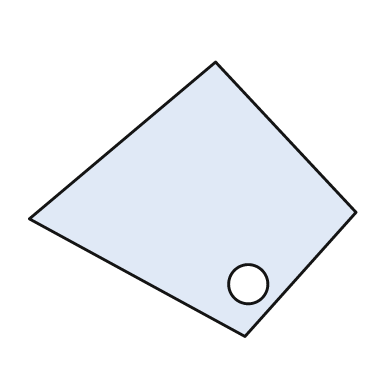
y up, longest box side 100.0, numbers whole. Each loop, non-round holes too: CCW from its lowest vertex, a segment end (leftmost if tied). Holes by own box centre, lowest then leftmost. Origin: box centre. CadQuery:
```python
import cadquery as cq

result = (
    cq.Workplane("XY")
    .moveTo(16.0, -42.0)
    .lineTo(50.0, -4.0)
    .lineTo(7.0, 42.0)
    .lineTo(-50.0, -6.0)
    .close()
    .moveTo(17.0, -26.0)
    .circle(6.0)
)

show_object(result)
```